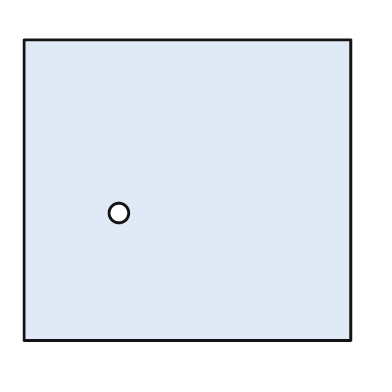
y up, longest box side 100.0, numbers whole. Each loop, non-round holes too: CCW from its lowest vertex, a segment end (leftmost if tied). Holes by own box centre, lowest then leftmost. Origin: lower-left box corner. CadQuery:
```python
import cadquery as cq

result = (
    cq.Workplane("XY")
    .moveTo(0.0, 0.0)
    .lineTo(100.0, 0.0)
    .lineTo(100.0, 92.0)
    .lineTo(0.0, 92.0)
    .close()
    .moveTo(29.0, 39.0)
    .circle(3.0)
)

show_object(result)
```